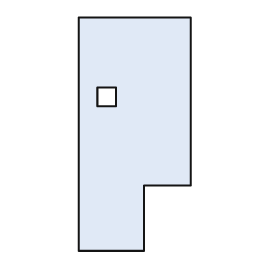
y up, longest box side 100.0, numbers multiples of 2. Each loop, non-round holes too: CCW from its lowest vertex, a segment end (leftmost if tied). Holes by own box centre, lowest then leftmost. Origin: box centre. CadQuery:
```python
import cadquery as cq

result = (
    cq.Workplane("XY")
    .moveTo(-24.0, -50.0)
    .lineTo(4.0, -50.0)
    .lineTo(4.0, -22.0)
    .lineTo(24.0, -22.0)
    .lineTo(24.0, 50.0)
    .lineTo(-24.0, 50.0)
    .close()
    .moveTo(-16.0, 12.0)
    .lineTo(-8.0, 12.0)
    .lineTo(-8.0, 20.0)
    .lineTo(-16.0, 20.0)
    .close()
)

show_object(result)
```